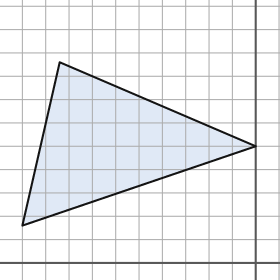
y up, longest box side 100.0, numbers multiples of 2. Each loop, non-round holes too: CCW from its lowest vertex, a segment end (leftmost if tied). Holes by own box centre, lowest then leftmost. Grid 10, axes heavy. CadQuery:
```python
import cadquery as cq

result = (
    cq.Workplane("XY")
    .moveTo(-100.0, 16.0)
    .lineTo(0.0, 50.0)
    .lineTo(-84.0, 86.0)
    .close()
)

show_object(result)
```